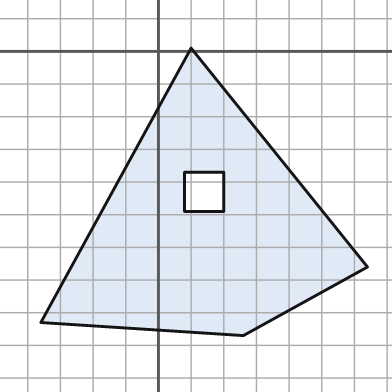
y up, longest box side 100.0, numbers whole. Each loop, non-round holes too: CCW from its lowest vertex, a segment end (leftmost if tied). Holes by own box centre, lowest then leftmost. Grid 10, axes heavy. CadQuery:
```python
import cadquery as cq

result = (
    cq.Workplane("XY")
    .moveTo(26.0, -87.0)
    .lineTo(64.0, -66.0)
    .lineTo(10.0, 1.0)
    .lineTo(-36.0, -83.0)
    .close()
    .moveTo(8.0, -49.0)
    .lineTo(20.0, -49.0)
    .lineTo(20.0, -37.0)
    .lineTo(8.0, -37.0)
    .close()
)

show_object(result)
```